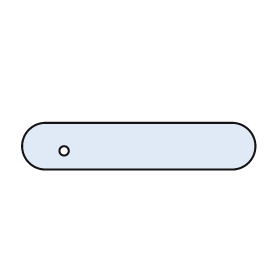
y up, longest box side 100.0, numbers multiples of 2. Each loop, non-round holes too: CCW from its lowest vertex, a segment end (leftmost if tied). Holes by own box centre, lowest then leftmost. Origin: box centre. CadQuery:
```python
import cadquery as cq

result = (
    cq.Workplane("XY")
    .moveTo(-40.0, -10.0)
    .lineTo(40.0, -10.0)
    .threePointArc((50.0, 0.0), (40.0, 10.0))
    .lineTo(-40.0, 10.0)
    .threePointArc((-50.0, 0.0), (-40.0, -10.0))
    .close()
    .moveTo(-32.0, -2.0)
    .circle(2.0)
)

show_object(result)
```